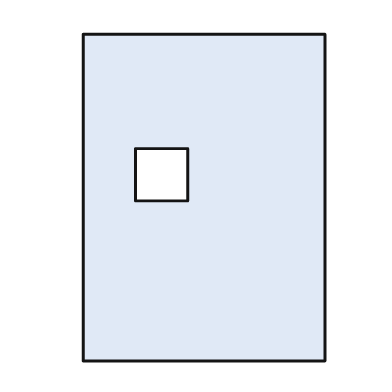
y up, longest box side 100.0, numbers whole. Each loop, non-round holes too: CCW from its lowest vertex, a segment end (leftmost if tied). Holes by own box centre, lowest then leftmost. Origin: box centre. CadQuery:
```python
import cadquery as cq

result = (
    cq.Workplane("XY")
    .moveTo(-37.0, -50.0)
    .lineTo(37.0, -50.0)
    .lineTo(37.0, 50.0)
    .lineTo(-37.0, 50.0)
    .close()
    .moveTo(-21.0, -1.0)
    .lineTo(-5.0, -1.0)
    .lineTo(-5.0, 15.0)
    .lineTo(-21.0, 15.0)
    .close()
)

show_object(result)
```